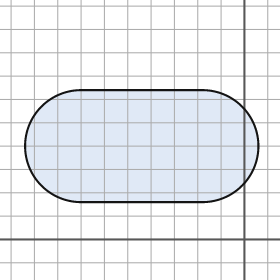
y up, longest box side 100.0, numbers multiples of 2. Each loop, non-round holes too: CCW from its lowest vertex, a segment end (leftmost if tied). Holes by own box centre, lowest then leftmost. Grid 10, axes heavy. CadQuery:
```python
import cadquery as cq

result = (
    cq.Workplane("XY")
    .moveTo(-70.0, 16.0)
    .lineTo(-18.0, 16.0)
    .threePointArc((6.0, 40.0), (-18.0, 64.0))
    .lineTo(-70.0, 64.0)
    .threePointArc((-94.0, 40.0), (-70.0, 16.0))
    .close()
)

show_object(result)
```